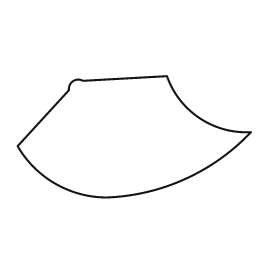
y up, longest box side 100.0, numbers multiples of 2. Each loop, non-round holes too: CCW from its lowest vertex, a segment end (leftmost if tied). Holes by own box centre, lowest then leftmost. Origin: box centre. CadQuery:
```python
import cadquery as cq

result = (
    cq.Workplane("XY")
    .moveTo(-12.0, -26.0)
    .threePointArc((22.0, -18.0), (50.0, 2.0))
    .threePointArc((28.0, 8.0), (14.0, 26.0))
    .lineTo(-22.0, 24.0)
    .threePointArc((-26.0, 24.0), (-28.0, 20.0))
    .lineTo(-50.0, -4.0)
    .threePointArc((-34.0, -20.0), (-12.0, -26.0))
    .close()
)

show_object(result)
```